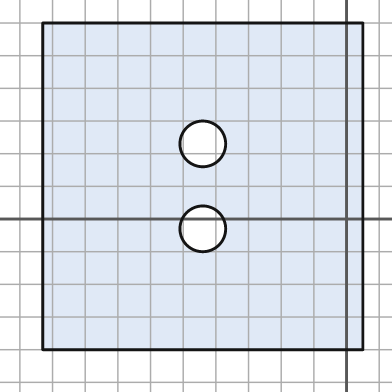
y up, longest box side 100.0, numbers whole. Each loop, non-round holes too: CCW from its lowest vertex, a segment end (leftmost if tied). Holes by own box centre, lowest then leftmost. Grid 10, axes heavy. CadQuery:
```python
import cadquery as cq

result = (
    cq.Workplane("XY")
    .moveTo(-93.0, -40.0)
    .lineTo(5.0, -40.0)
    .lineTo(5.0, 60.0)
    .lineTo(-93.0, 60.0)
    .close()
    .moveTo(-44.0, -3.0)
    .circle(7.0)
    .moveTo(-44.0, 23.0)
    .circle(7.0)
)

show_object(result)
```